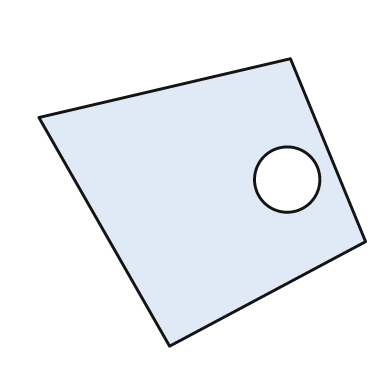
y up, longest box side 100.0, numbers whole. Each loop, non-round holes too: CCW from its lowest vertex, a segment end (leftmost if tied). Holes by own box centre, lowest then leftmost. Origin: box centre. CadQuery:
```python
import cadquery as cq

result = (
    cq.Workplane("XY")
    .moveTo(-10.0, -44.0)
    .lineTo(50.0, -12.0)
    .lineTo(27.0, 44.0)
    .lineTo(-50.0, 26.0)
    .close()
    .moveTo(26.0, 7.0)
    .circle(10.0)
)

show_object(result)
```